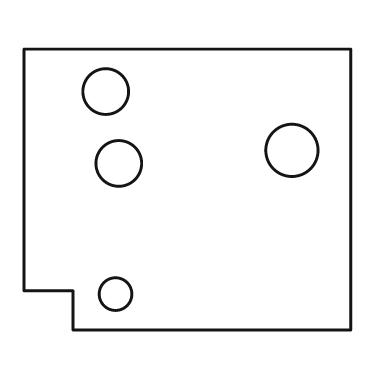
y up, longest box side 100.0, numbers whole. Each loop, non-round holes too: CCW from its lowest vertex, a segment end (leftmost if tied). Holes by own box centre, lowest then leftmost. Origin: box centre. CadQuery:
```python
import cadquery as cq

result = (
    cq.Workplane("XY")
    .moveTo(-35.0, -43.0)
    .lineTo(50.0, -43.0)
    .lineTo(50.0, 43.0)
    .lineTo(-50.0, 43.0)
    .lineTo(-50.0, -31.0)
    .lineTo(-35.0, -31.0)
    .close()
    .moveTo(-22.0, -32.0)
    .circle(5.0)
    .moveTo(-21.0, 8.0)
    .circle(7.0)
    .moveTo(32.0, 12.0)
    .circle(8.0)
    .moveTo(-25.0, 30.0)
    .circle(7.0)
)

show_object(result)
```